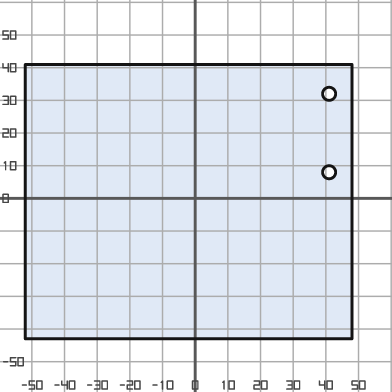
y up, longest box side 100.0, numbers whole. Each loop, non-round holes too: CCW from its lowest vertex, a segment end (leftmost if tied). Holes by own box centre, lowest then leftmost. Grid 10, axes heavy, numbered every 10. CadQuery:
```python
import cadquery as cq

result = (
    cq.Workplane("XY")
    .moveTo(-52.0, -43.0)
    .lineTo(48.0, -43.0)
    .lineTo(48.0, 41.0)
    .lineTo(-52.0, 41.0)
    .close()
    .moveTo(41.0, 8.0)
    .circle(2.0)
    .moveTo(41.0, 32.0)
    .circle(2.0)
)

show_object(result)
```